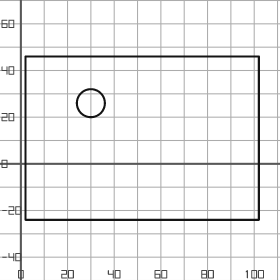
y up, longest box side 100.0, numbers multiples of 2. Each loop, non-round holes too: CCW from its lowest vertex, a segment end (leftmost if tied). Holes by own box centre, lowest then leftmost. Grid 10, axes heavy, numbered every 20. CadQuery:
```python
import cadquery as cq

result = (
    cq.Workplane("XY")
    .moveTo(2.0, -24.0)
    .lineTo(102.0, -24.0)
    .lineTo(102.0, 46.0)
    .lineTo(2.0, 46.0)
    .close()
    .moveTo(30.0, 26.0)
    .circle(6.0)
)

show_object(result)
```